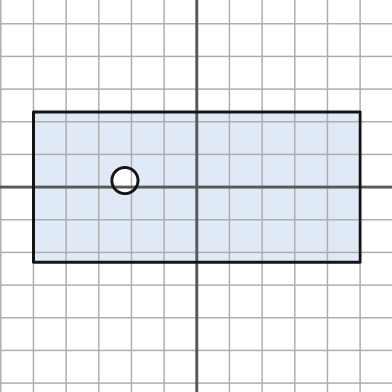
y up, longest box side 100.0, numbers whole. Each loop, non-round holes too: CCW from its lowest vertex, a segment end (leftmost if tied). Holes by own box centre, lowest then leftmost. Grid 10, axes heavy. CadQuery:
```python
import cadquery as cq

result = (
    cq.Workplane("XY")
    .moveTo(-50.0, -23.0)
    .lineTo(50.0, -23.0)
    .lineTo(50.0, 23.0)
    .lineTo(-50.0, 23.0)
    .close()
    .moveTo(-22.0, 2.0)
    .circle(4.0)
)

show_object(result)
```